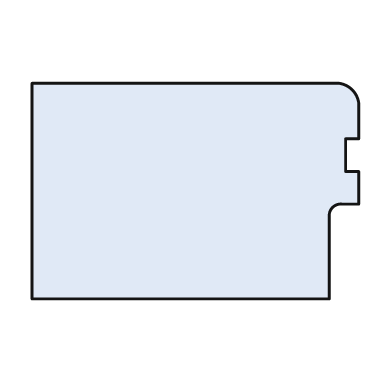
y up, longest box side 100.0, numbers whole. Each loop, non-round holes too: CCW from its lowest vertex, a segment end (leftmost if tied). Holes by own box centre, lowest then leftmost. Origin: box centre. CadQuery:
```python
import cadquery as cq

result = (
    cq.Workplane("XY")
    .moveTo(-50.0, -33.0)
    .lineTo(41.0, -33.0)
    .lineTo(41.0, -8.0)
    .threePointArc((42.0, -5.0), (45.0, -4.0))
    .lineTo(50.0, -4.0)
    .lineTo(50.0, 6.0)
    .lineTo(46.0, 6.0)
    .lineTo(46.0, 16.0)
    .lineTo(50.0, 16.0)
    .lineTo(50.0, 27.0)
    .threePointArc((48.0, 31.0), (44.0, 33.0))
    .lineTo(-50.0, 33.0)
    .close()
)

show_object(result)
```